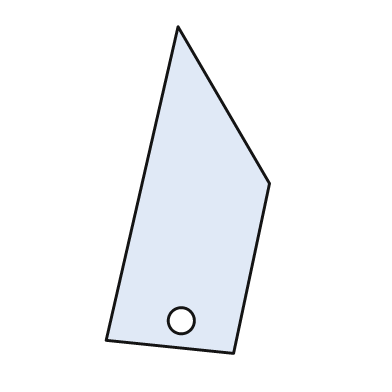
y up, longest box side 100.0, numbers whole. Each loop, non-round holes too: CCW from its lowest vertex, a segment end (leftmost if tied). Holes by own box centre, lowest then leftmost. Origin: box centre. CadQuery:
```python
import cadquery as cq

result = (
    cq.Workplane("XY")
    .moveTo(14.0, -50.0)
    .lineTo(25.0, 2.0)
    .lineTo(-3.0, 50.0)
    .lineTo(-25.0, -46.0)
    .close()
    .moveTo(-2.0, -40.0)
    .circle(4.0)
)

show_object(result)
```